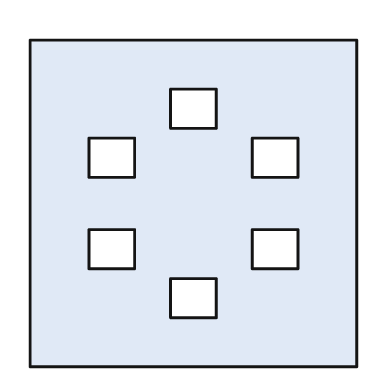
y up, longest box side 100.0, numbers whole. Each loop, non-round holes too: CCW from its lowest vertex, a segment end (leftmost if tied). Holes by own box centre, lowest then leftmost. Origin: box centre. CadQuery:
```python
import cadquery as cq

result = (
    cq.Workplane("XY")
    .moveTo(-50.0, -50.0)
    .lineTo(50.0, -50.0)
    .lineTo(50.0, 50.0)
    .lineTo(-50.0, 50.0)
    .close()
    .moveTo(-7.0, -35.0)
    .lineTo(7.0, -35.0)
    .lineTo(7.0, -23.0)
    .lineTo(-7.0, -23.0)
    .close()
    .moveTo(-32.0, -20.0)
    .lineTo(-18.0, -20.0)
    .lineTo(-18.0, -8.0)
    .lineTo(-32.0, -8.0)
    .close()
    .moveTo(18.0, -20.0)
    .lineTo(32.0, -20.0)
    .lineTo(32.0, -8.0)
    .lineTo(18.0, -8.0)
    .close()
    .moveTo(-32.0, 8.0)
    .lineTo(-18.0, 8.0)
    .lineTo(-18.0, 20.0)
    .lineTo(-32.0, 20.0)
    .close()
    .moveTo(18.0, 8.0)
    .lineTo(32.0, 8.0)
    .lineTo(32.0, 20.0)
    .lineTo(18.0, 20.0)
    .close()
    .moveTo(-7.0, 23.0)
    .lineTo(7.0, 23.0)
    .lineTo(7.0, 35.0)
    .lineTo(-7.0, 35.0)
    .close()
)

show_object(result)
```